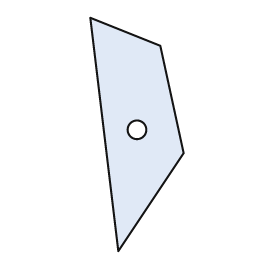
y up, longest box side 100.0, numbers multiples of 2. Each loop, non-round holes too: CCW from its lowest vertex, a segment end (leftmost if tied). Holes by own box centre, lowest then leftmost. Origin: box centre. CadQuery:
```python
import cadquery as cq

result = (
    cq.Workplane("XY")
    .moveTo(-8.0, -50.0)
    .lineTo(20.0, -8.0)
    .lineTo(10.0, 38.0)
    .lineTo(-20.0, 50.0)
    .close()
    .moveTo(0.0, 2.0)
    .circle(4.0)
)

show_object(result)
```